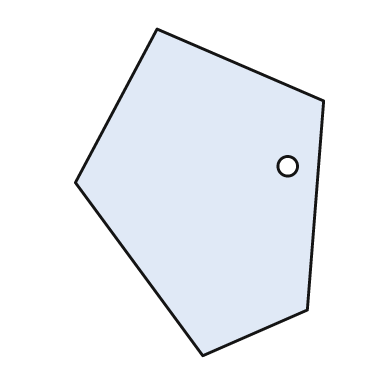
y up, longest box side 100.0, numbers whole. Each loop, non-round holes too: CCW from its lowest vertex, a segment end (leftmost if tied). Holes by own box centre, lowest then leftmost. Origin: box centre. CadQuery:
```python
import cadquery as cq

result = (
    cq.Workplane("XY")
    .moveTo(1.0, -50.0)
    .lineTo(33.0, -36.0)
    .lineTo(38.0, 28.0)
    .lineTo(-13.0, 50.0)
    .lineTo(-38.0, 3.0)
    .close()
    .moveTo(27.0, 8.0)
    .circle(3.0)
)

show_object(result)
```